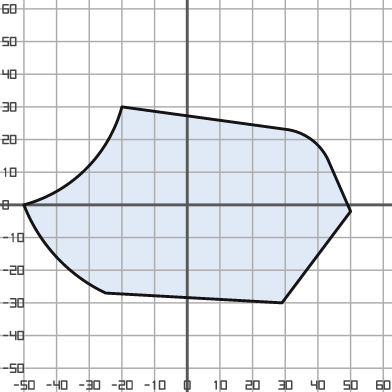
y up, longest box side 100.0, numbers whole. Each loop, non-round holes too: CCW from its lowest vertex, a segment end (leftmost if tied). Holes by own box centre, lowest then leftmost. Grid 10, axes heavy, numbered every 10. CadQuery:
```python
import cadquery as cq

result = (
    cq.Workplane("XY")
    .moveTo(29.0, -30.0)
    .lineTo(50.0, -2.0)
    .lineTo(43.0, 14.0)
    .threePointArc((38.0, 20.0), (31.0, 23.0))
    .lineTo(-20.0, 30.0)
    .threePointArc((-31.0, 11.0), (-50.0, 0.0))
    .threePointArc((-40.0, -16.0), (-25.0, -27.0))
    .close()
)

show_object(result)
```